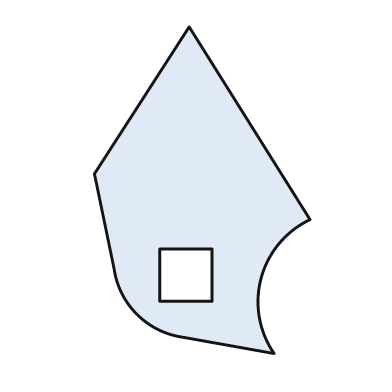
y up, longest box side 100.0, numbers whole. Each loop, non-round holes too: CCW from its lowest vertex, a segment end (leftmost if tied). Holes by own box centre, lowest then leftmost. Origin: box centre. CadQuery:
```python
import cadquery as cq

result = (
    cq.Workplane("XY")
    .moveTo(22.0, -50.0)
    .threePointArc((18.0, -27.0), (33.0, -9.0))
    .lineTo(-4.0, 50.0)
    .lineTo(-33.0, 5.0)
    .lineTo(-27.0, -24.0)
    .threePointArc((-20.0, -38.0), (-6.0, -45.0))
    .close()
    .moveTo(-13.0, -34.0)
    .lineTo(3.0, -34.0)
    .lineTo(3.0, -18.0)
    .lineTo(-13.0, -18.0)
    .close()
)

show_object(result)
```